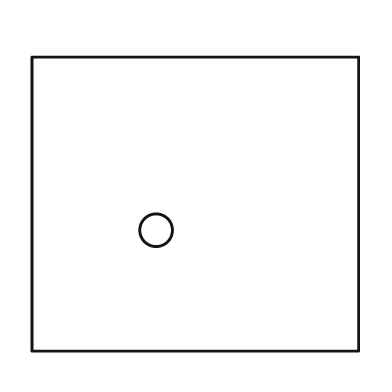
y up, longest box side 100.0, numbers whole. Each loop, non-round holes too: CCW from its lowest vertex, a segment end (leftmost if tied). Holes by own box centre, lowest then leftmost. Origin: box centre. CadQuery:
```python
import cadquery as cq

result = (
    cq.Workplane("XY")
    .moveTo(-50.0, -45.0)
    .lineTo(50.0, -45.0)
    .lineTo(50.0, 45.0)
    .lineTo(-50.0, 45.0)
    .close()
    .moveTo(-12.0, -8.0)
    .circle(5.0)
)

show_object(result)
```